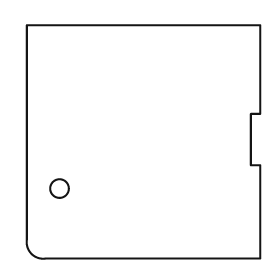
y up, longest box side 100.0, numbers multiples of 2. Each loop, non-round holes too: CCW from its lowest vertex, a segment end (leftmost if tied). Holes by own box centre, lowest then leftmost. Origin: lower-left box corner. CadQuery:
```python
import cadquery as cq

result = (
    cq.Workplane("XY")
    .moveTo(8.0, 0.0)
    .lineTo(100.0, 0.0)
    .lineTo(100.0, 40.0)
    .lineTo(96.0, 40.0)
    .lineTo(96.0, 62.0)
    .lineTo(100.0, 62.0)
    .lineTo(100.0, 100.0)
    .lineTo(0.0, 100.0)
    .lineTo(0.0, 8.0)
    .threePointArc((2.0, 2.0), (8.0, 0.0))
    .close()
    .moveTo(14.0, 30.0)
    .circle(4.0)
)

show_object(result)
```